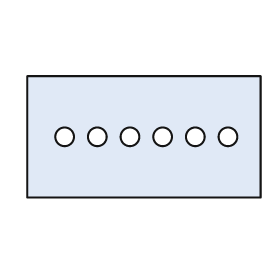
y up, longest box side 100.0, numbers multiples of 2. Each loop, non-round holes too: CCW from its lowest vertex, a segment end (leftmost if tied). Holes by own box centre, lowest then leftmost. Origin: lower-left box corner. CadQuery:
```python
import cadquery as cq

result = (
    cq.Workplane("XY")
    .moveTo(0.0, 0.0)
    .lineTo(100.0, 0.0)
    .lineTo(100.0, 52.0)
    .lineTo(0.0, 52.0)
    .close()
    .moveTo(16.0, 26.0)
    .circle(4.0)
    .moveTo(30.0, 26.0)
    .circle(4.0)
    .moveTo(44.0, 26.0)
    .circle(4.0)
    .moveTo(58.0, 26.0)
    .circle(4.0)
    .moveTo(72.0, 26.0)
    .circle(4.0)
    .moveTo(86.0, 26.0)
    .circle(4.0)
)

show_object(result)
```